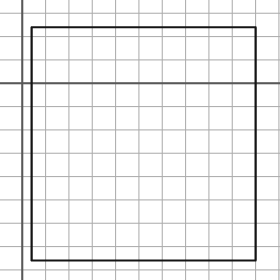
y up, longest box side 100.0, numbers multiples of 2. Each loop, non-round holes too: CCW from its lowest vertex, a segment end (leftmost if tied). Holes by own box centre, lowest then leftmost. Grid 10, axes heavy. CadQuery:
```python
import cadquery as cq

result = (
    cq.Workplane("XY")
    .moveTo(4.0, -76.0)
    .lineTo(100.0, -76.0)
    .lineTo(100.0, 24.0)
    .lineTo(4.0, 24.0)
    .close()
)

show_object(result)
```